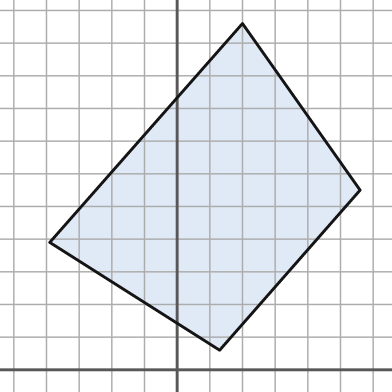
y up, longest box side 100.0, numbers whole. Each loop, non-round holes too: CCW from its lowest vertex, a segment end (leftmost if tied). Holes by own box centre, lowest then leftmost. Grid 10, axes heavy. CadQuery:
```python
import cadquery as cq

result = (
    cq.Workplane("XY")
    .moveTo(13.0, 6.0)
    .lineTo(56.0, 55.0)
    .lineTo(20.0, 106.0)
    .lineTo(-39.0, 39.0)
    .close()
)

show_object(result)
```